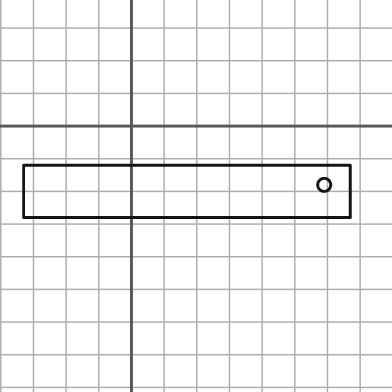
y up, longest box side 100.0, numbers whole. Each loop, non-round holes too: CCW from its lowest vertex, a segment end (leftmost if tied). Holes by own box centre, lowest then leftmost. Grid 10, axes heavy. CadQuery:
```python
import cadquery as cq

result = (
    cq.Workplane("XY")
    .moveTo(-33.0, -28.0)
    .lineTo(67.0, -28.0)
    .lineTo(67.0, -12.0)
    .lineTo(-33.0, -12.0)
    .close()
    .moveTo(59.0, -18.0)
    .circle(2.0)
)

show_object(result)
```